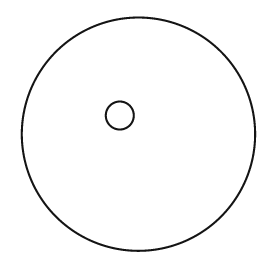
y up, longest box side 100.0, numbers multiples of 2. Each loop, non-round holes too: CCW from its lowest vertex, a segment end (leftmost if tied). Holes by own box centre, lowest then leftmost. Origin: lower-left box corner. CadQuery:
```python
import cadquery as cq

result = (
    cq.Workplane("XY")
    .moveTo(50.0, 50.0)
    .circle(50.0)
    .moveTo(42.0, 58.0)
    .circle(6.0)
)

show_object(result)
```